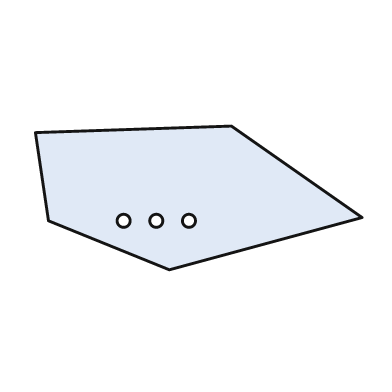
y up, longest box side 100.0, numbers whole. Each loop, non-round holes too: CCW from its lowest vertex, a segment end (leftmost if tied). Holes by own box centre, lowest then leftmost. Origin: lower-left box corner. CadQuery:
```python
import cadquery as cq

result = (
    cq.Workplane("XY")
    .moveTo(41.0, 0.0)
    .lineTo(100.0, 16.0)
    .lineTo(60.0, 44.0)
    .lineTo(0.0, 42.0)
    .lineTo(4.0, 15.0)
    .close()
    .moveTo(27.0, 15.0)
    .circle(2.0)
    .moveTo(37.0, 15.0)
    .circle(2.0)
    .moveTo(47.0, 15.0)
    .circle(2.0)
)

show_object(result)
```